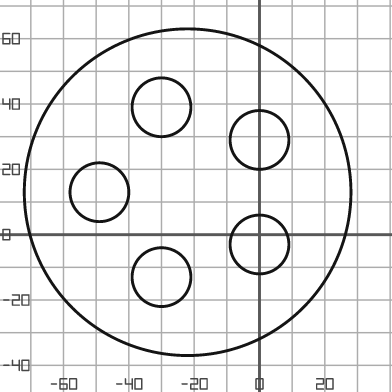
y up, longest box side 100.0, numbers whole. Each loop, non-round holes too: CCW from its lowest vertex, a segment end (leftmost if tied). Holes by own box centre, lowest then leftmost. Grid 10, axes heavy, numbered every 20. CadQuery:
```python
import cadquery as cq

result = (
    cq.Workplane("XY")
    .moveTo(-22.0, 13.0)
    .circle(50.0)
    .moveTo(-30.0, -13.0)
    .circle(9.0)
    .moveTo(0.0, -3.0)
    .circle(9.0)
    .moveTo(-49.0, 13.0)
    .circle(9.0)
    .moveTo(0.0, 29.0)
    .circle(9.0)
    .moveTo(-30.0, 39.0)
    .circle(9.0)
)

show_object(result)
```